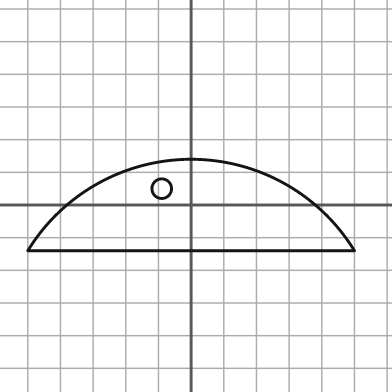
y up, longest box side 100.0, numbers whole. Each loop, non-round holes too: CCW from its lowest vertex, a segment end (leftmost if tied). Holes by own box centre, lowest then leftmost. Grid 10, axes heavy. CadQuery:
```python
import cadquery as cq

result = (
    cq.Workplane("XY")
    .moveTo(-50.0, -14.0)
    .lineTo(50.0, -14.0)
    .threePointArc((0.0, 14.0), (-50.0, -14.0))
    .close()
    .moveTo(-9.0, 5.0)
    .circle(3.0)
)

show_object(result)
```